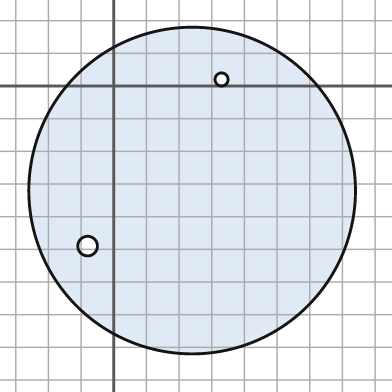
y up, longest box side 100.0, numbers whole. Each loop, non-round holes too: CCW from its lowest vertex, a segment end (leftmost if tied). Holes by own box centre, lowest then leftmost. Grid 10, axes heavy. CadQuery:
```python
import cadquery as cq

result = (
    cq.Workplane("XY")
    .moveTo(24.0, -32.0)
    .circle(50.0)
    .moveTo(-8.0, -49.0)
    .circle(3.0)
    .moveTo(33.0, 2.0)
    .circle(2.0)
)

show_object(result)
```